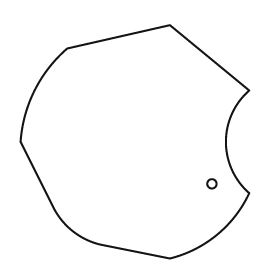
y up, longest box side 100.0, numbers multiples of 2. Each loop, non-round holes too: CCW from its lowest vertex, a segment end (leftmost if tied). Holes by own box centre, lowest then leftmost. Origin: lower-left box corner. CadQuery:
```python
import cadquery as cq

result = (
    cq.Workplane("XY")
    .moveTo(64.0, 0.0)
    .threePointArc((84.0, 10.0), (98.0, 28.0))
    .threePointArc((88.0, 50.0), (98.0, 72.0))
    .lineTo(64.0, 100.0)
    .lineTo(20.0, 90.0)
    .threePointArc((6.0, 72.0), (0.0, 50.0))
    .lineTo(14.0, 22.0)
    .threePointArc((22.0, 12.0), (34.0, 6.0))
    .close()
    .moveTo(82.0, 32.0)
    .circle(2.0)
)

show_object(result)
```